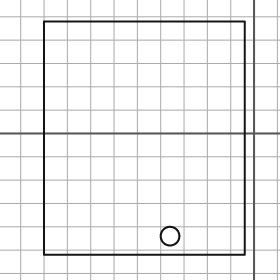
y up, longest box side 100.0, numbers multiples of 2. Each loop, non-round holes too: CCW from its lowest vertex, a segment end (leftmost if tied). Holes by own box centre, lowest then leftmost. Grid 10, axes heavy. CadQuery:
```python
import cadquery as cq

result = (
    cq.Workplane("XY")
    .moveTo(-90.0, -52.0)
    .lineTo(-4.0, -52.0)
    .lineTo(-4.0, 48.0)
    .lineTo(-90.0, 48.0)
    .close()
    .moveTo(-36.0, -44.0)
    .circle(4.0)
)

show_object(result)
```